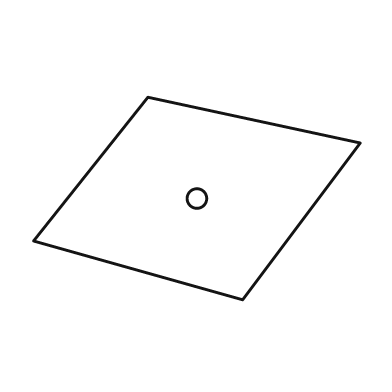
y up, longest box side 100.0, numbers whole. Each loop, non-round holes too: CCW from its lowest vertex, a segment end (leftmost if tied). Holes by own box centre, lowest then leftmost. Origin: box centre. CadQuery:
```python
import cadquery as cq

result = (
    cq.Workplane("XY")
    .moveTo(14.0, -31.0)
    .lineTo(50.0, 17.0)
    .lineTo(-15.0, 31.0)
    .lineTo(-50.0, -13.0)
    .close()
    .moveTo(0.0, 0.0)
    .circle(3.0)
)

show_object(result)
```